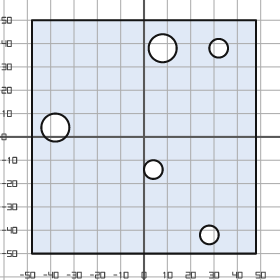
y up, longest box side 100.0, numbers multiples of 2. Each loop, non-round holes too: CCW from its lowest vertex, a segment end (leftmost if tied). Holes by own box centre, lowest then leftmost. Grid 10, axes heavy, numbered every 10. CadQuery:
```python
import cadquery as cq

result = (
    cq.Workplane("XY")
    .moveTo(-48.0, -50.0)
    .lineTo(48.0, -50.0)
    .lineTo(48.0, 50.0)
    .lineTo(-48.0, 50.0)
    .close()
    .moveTo(28.0, -42.0)
    .circle(4.0)
    .moveTo(4.0, -14.0)
    .circle(4.0)
    .moveTo(-38.0, 4.0)
    .circle(6.0)
    .moveTo(8.0, 38.0)
    .circle(6.0)
    .moveTo(32.0, 38.0)
    .circle(4.0)
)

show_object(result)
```